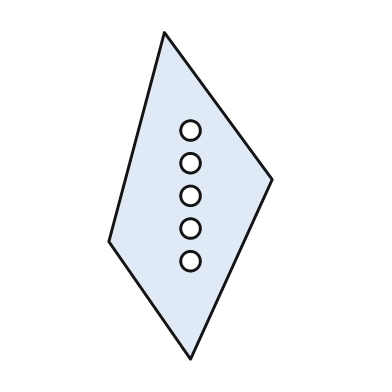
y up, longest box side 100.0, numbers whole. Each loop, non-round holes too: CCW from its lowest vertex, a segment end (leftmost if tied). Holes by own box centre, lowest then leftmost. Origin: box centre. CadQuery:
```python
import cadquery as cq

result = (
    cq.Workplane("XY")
    .moveTo(0.0, -50.0)
    .lineTo(25.0, 5.0)
    .lineTo(-8.0, 50.0)
    .lineTo(-25.0, -14.0)
    .close()
    .moveTo(0.0, -20.0)
    .circle(3.0)
    .moveTo(0.0, -10.0)
    .circle(3.0)
    .moveTo(0.0, 0.0)
    .circle(3.0)
    .moveTo(0.0, 10.0)
    .circle(3.0)
    .moveTo(0.0, 20.0)
    .circle(3.0)
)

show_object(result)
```